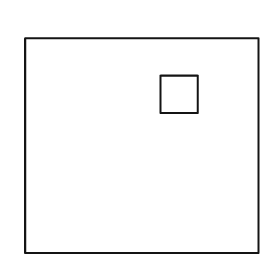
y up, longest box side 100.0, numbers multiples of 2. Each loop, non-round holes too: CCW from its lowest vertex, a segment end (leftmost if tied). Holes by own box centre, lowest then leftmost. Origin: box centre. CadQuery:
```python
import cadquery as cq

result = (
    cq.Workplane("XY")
    .moveTo(-50.0, -46.0)
    .lineTo(50.0, -46.0)
    .lineTo(50.0, 46.0)
    .lineTo(-50.0, 46.0)
    .close()
    .moveTo(8.0, 14.0)
    .lineTo(24.0, 14.0)
    .lineTo(24.0, 30.0)
    .lineTo(8.0, 30.0)
    .close()
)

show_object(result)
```